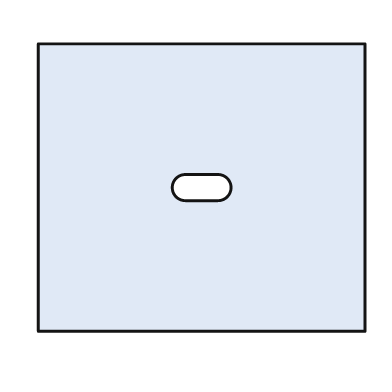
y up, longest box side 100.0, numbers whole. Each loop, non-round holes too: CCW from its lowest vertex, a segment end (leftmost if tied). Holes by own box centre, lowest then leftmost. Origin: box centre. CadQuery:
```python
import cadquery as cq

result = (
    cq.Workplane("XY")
    .moveTo(-50.0, -44.0)
    .lineTo(50.0, -44.0)
    .lineTo(50.0, 44.0)
    .lineTo(-50.0, 44.0)
    .close()
    .moveTo(-5.0, -4.0)
    .lineTo(5.0, -4.0)
    .threePointArc((9.0, 0.0), (5.0, 4.0))
    .lineTo(-5.0, 4.0)
    .threePointArc((-9.0, 0.0), (-5.0, -4.0))
    .close()
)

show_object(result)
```